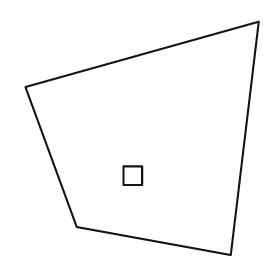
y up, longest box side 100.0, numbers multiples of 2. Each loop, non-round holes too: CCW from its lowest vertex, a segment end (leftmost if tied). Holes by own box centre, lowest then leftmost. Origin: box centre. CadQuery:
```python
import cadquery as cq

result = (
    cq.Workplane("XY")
    .moveTo(38.0, -50.0)
    .lineTo(50.0, 50.0)
    .lineTo(-50.0, 22.0)
    .lineTo(-28.0, -38.0)
    .close()
    .moveTo(-8.0, -20.0)
    .lineTo(0.0, -20.0)
    .lineTo(0.0, -12.0)
    .lineTo(-8.0, -12.0)
    .close()
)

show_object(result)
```